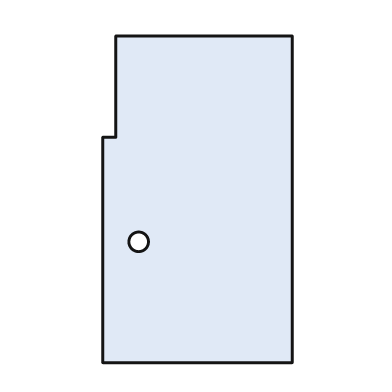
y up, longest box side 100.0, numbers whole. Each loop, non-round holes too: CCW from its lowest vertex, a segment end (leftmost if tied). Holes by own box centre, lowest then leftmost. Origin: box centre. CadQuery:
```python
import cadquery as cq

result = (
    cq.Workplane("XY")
    .moveTo(-29.0, -50.0)
    .lineTo(29.0, -50.0)
    .lineTo(29.0, 50.0)
    .lineTo(-25.0, 50.0)
    .lineTo(-25.0, 19.0)
    .lineTo(-29.0, 19.0)
    .close()
    .moveTo(-18.0, -13.0)
    .circle(3.0)
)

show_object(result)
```